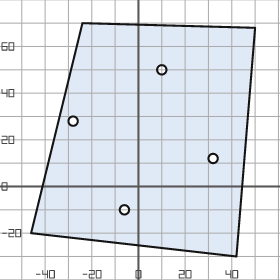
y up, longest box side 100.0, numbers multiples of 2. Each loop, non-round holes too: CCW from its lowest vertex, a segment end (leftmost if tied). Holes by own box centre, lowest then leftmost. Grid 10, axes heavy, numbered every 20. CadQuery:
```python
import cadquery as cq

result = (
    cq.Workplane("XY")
    .moveTo(42.0, -30.0)
    .lineTo(50.0, 68.0)
    .lineTo(-24.0, 70.0)
    .lineTo(-46.0, -20.0)
    .close()
    .moveTo(-6.0, -10.0)
    .circle(2.0)
    .moveTo(32.0, 12.0)
    .circle(2.0)
    .moveTo(-28.0, 28.0)
    .circle(2.0)
    .moveTo(10.0, 50.0)
    .circle(2.0)
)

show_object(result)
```